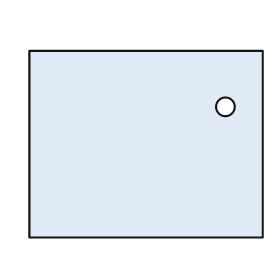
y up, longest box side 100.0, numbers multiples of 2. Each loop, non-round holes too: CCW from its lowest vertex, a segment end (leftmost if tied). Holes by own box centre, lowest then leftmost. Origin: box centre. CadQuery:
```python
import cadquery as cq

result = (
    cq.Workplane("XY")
    .moveTo(-50.0, -40.0)
    .lineTo(50.0, -40.0)
    .lineTo(50.0, 40.0)
    .lineTo(-50.0, 40.0)
    .close()
    .moveTo(34.0, 16.0)
    .circle(4.0)
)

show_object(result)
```